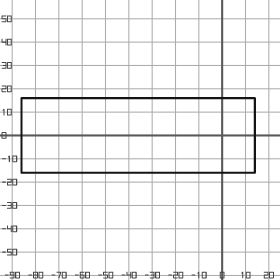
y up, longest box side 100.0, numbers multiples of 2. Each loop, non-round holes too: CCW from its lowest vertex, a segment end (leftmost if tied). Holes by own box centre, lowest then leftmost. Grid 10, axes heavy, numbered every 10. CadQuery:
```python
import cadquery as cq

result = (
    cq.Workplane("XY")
    .moveTo(-86.0, -16.0)
    .lineTo(14.0, -16.0)
    .lineTo(14.0, 16.0)
    .lineTo(-86.0, 16.0)
    .close()
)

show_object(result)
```